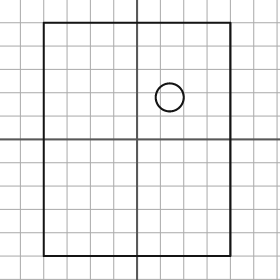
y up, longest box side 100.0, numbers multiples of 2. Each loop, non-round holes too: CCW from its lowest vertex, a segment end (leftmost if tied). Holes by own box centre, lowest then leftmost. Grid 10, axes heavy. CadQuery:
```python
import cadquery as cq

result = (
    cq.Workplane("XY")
    .moveTo(-40.0, -50.0)
    .lineTo(40.0, -50.0)
    .lineTo(40.0, 50.0)
    .lineTo(-40.0, 50.0)
    .close()
    .moveTo(14.0, 18.0)
    .circle(6.0)
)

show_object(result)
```